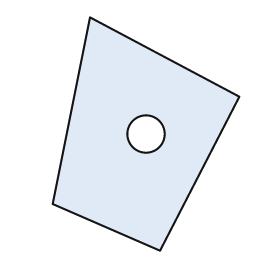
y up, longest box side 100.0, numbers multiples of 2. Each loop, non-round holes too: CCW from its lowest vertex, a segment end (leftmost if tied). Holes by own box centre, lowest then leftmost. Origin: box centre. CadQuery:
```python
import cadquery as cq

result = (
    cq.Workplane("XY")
    .moveTo(6.0, -50.0)
    .lineTo(40.0, 16.0)
    .lineTo(-24.0, 50.0)
    .lineTo(-40.0, -30.0)
    .close()
    .moveTo(0.0, 0.0)
    .circle(8.0)
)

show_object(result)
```